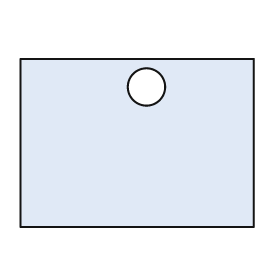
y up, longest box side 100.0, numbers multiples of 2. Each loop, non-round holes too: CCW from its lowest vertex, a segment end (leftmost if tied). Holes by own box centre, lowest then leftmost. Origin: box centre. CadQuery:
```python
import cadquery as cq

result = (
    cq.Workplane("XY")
    .moveTo(-50.0, -36.0)
    .lineTo(50.0, -36.0)
    .lineTo(50.0, 36.0)
    .lineTo(-50.0, 36.0)
    .close()
    .moveTo(4.0, 24.0)
    .circle(8.0)
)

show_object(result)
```